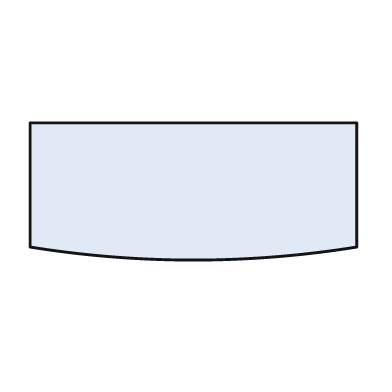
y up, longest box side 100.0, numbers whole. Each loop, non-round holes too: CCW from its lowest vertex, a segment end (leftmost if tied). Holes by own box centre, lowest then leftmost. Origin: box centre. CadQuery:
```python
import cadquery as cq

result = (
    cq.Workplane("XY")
    .moveTo(-50.0, -17.0)
    .threePointArc((0.0, -21.0), (50.0, -17.0))
    .lineTo(50.0, 21.0)
    .lineTo(-50.0, 21.0)
    .close()
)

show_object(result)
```